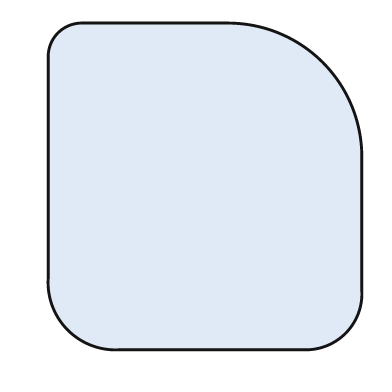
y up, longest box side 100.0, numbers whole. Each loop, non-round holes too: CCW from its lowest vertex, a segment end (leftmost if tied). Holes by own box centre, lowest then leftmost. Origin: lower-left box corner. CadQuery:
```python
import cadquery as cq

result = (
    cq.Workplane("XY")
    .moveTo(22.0, 0.0)
    .lineTo(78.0, 0.0)
    .threePointArc((91.0, 5.0), (96.0, 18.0))
    .lineTo(96.0, 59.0)
    .threePointArc((84.0, 88.0), (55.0, 100.0))
    .lineTo(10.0, 100.0)
    .threePointArc((3.0, 97.0), (0.0, 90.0))
    .lineTo(0.0, 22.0)
    .threePointArc((6.0, 6.0), (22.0, 0.0))
    .close()
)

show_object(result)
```